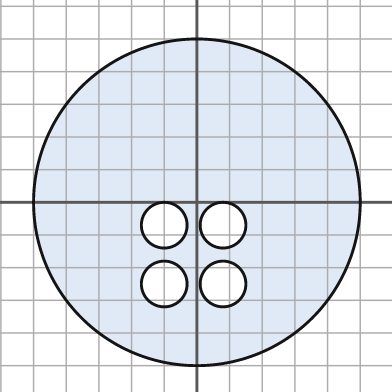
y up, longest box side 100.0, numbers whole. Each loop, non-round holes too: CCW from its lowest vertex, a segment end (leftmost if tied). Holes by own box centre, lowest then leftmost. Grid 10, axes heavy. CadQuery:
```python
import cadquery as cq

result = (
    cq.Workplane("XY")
    .moveTo(0.0, 0.0)
    .circle(50.0)
    .moveTo(-10.0, -25.0)
    .circle(7.0)
    .moveTo(8.0, -25.0)
    .circle(7.0)
    .moveTo(-10.0, -7.0)
    .circle(7.0)
    .moveTo(8.0, -7.0)
    .circle(7.0)
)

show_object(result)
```